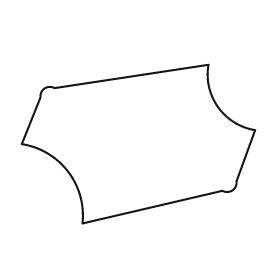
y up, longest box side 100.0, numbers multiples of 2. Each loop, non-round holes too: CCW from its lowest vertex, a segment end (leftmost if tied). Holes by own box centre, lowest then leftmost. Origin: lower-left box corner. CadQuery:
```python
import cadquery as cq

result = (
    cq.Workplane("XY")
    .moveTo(26.0, 0.0)
    .lineTo(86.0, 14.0)
    .threePointArc((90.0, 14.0), (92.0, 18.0))
    .lineTo(100.0, 40.0)
    .threePointArc((84.0, 50.0), (80.0, 68.0))
    .lineTo(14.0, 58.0)
    .threePointArc((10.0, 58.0), (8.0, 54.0))
    .lineTo(0.0, 34.0)
    .threePointArc((20.0, 22.0), (26.0, 0.0))
    .close()
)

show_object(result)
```